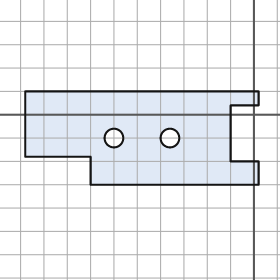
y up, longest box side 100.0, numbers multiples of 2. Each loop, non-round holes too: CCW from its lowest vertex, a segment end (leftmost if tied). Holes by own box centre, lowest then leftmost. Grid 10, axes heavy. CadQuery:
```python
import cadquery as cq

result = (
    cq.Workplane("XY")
    .moveTo(-70.0, -30.0)
    .lineTo(2.0, -30.0)
    .lineTo(2.0, -20.0)
    .lineTo(-10.0, -20.0)
    .lineTo(-10.0, 4.0)
    .lineTo(2.0, 4.0)
    .lineTo(2.0, 10.0)
    .lineTo(-98.0, 10.0)
    .lineTo(-98.0, -18.0)
    .lineTo(-70.0, -18.0)
    .close()
    .moveTo(-60.0, -10.0)
    .circle(4.0)
    .moveTo(-36.0, -10.0)
    .circle(4.0)
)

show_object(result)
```